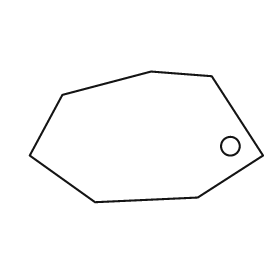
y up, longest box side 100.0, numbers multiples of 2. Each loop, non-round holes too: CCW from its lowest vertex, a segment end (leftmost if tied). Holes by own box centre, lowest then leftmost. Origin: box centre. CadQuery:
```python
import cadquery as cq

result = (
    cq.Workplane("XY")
    .moveTo(-22.0, -28.0)
    .lineTo(22.0, -26.0)
    .lineTo(50.0, -8.0)
    .lineTo(28.0, 26.0)
    .lineTo(2.0, 28.0)
    .lineTo(-36.0, 18.0)
    .lineTo(-50.0, -8.0)
    .close()
    .moveTo(36.0, -4.0)
    .circle(4.0)
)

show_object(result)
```